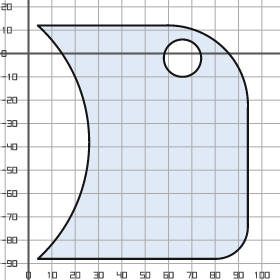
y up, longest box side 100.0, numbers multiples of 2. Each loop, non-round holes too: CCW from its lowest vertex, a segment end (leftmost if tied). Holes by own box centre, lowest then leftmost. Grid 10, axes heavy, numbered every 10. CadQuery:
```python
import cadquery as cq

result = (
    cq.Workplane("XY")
    .moveTo(4.0, -88.0)
    .lineTo(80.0, -88.0)
    .threePointArc((90.0, -84.0), (94.0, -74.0))
    .lineTo(94.0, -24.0)
    .threePointArc((84.0, 2.0), (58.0, 12.0))
    .lineTo(4.0, 12.0)
    .threePointArc((26.0, -38.0), (4.0, -88.0))
    .close()
    .moveTo(66.0, -2.0)
    .circle(8.0)
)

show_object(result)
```